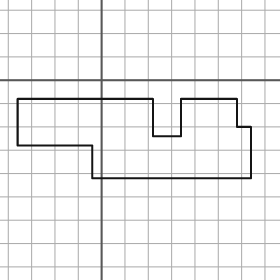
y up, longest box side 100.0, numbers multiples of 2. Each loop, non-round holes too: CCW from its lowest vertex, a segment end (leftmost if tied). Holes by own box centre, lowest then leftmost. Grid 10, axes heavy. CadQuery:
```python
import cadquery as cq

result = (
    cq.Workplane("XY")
    .moveTo(-4.0, -42.0)
    .lineTo(64.0, -42.0)
    .lineTo(64.0, -20.0)
    .lineTo(58.0, -20.0)
    .lineTo(58.0, -8.0)
    .lineTo(34.0, -8.0)
    .lineTo(34.0, -24.0)
    .lineTo(22.0, -24.0)
    .lineTo(22.0, -8.0)
    .lineTo(-36.0, -8.0)
    .lineTo(-36.0, -28.0)
    .lineTo(-4.0, -28.0)
    .close()
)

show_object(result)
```